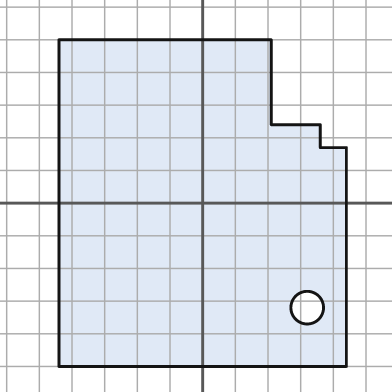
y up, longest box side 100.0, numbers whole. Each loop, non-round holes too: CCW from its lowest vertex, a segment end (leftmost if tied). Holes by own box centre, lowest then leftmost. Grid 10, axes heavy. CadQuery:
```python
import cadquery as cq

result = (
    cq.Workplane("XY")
    .moveTo(-44.0, -50.0)
    .lineTo(44.0, -50.0)
    .lineTo(44.0, 17.0)
    .lineTo(36.0, 17.0)
    .lineTo(36.0, 24.0)
    .lineTo(21.0, 24.0)
    .lineTo(21.0, 50.0)
    .lineTo(-44.0, 50.0)
    .close()
    .moveTo(32.0, -32.0)
    .circle(5.0)
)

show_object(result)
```